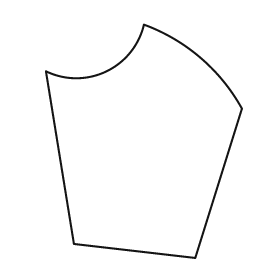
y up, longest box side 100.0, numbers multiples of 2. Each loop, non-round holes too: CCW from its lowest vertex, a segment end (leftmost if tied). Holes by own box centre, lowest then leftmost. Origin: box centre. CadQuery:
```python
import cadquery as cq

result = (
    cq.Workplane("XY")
    .moveTo(22.0, -50.0)
    .lineTo(42.0, 14.0)
    .threePointArc((24.0, 36.0), (0.0, 50.0))
    .threePointArc((-16.0, 30.0), (-42.0, 30.0))
    .lineTo(-30.0, -44.0)
    .close()
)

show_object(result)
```